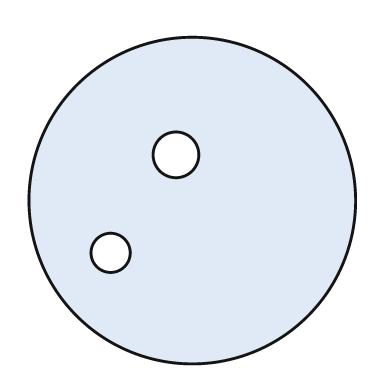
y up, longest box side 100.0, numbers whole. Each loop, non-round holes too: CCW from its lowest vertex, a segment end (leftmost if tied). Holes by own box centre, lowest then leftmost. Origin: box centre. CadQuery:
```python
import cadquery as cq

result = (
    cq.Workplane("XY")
    .moveTo(0.0, 0.0)
    .circle(50.0)
    .moveTo(-25.0, -16.0)
    .circle(6.0)
    .moveTo(-5.0, 14.0)
    .circle(7.0)
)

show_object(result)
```